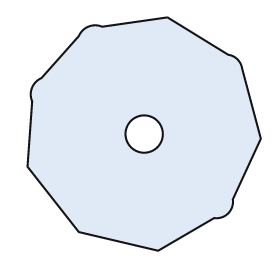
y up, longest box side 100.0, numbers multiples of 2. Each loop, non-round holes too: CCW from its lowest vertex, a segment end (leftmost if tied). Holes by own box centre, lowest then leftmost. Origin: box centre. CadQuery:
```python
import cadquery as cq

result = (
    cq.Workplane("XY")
    .moveTo(6.0, -50.0)
    .lineTo(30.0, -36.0)
    .threePointArc((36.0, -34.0), (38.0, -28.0))
    .lineTo(50.0, -2.0)
    .lineTo(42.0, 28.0)
    .threePointArc((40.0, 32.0), (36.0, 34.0))
    .lineTo(10.0, 50.0)
    .lineTo(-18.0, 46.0)
    .threePointArc((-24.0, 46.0), (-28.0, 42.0))
    .lineTo(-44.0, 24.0)
    .threePointArc((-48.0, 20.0), (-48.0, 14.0))
    .lineTo(-50.0, -14.0)
    .lineTo(-28.0, -42.0)
    .close()
    .moveTo(0.0, 0.0)
    .circle(8.0)
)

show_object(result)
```